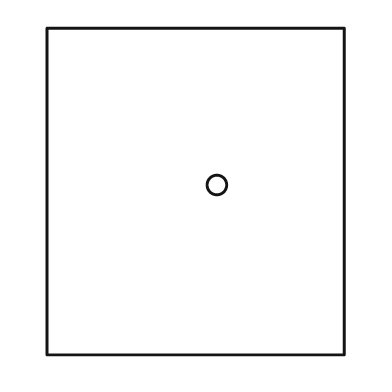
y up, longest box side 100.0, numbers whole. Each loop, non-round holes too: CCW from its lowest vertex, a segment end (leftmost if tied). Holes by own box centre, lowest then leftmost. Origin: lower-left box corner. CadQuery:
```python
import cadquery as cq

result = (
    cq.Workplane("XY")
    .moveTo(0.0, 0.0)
    .lineTo(91.0, 0.0)
    .lineTo(91.0, 100.0)
    .lineTo(0.0, 100.0)
    .close()
    .moveTo(52.0, 52.0)
    .circle(3.0)
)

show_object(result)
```